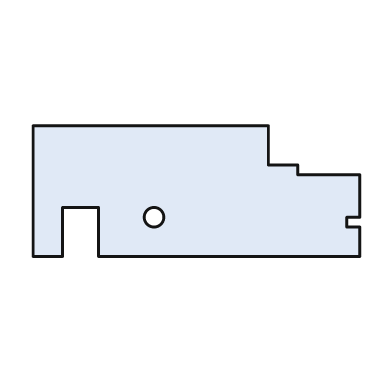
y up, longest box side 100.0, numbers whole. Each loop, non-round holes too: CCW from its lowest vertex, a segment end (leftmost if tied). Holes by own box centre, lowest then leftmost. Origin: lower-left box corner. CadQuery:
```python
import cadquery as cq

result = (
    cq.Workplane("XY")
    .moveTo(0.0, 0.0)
    .lineTo(9.0, 0.0)
    .lineTo(9.0, 15.0)
    .lineTo(20.0, 15.0)
    .lineTo(20.0, 0.0)
    .lineTo(100.0, 0.0)
    .lineTo(100.0, 9.0)
    .lineTo(96.0, 9.0)
    .lineTo(96.0, 12.0)
    .lineTo(100.0, 12.0)
    .lineTo(100.0, 25.0)
    .lineTo(81.0, 25.0)
    .lineTo(81.0, 28.0)
    .lineTo(72.0, 28.0)
    .lineTo(72.0, 40.0)
    .lineTo(0.0, 40.0)
    .close()
    .moveTo(37.0, 12.0)
    .circle(3.0)
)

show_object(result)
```